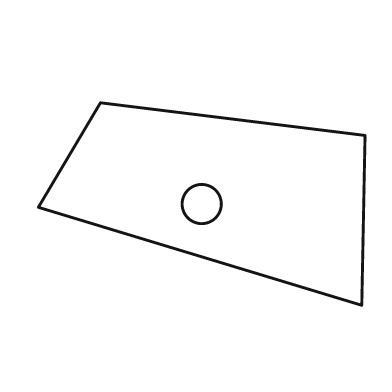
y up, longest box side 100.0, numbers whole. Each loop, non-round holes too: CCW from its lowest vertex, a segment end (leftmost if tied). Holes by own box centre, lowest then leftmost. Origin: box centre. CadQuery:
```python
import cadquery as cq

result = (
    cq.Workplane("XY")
    .moveTo(49.0, -31.0)
    .lineTo(50.0, 21.0)
    .lineTo(-31.0, 31.0)
    .lineTo(-50.0, -1.0)
    .close()
    .moveTo(0.0, 0.0)
    .circle(6.0)
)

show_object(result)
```